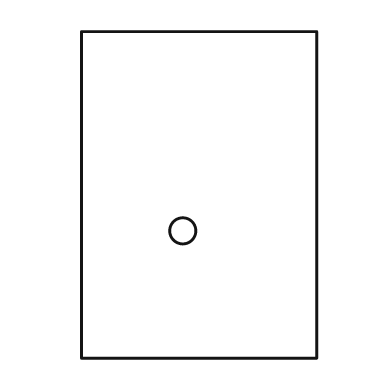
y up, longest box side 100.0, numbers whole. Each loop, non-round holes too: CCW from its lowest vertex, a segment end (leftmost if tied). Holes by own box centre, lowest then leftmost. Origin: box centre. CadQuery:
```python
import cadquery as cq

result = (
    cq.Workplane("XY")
    .moveTo(-36.0, -50.0)
    .lineTo(36.0, -50.0)
    .lineTo(36.0, 50.0)
    .lineTo(-36.0, 50.0)
    .close()
    .moveTo(-5.0, -11.0)
    .circle(4.0)
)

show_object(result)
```